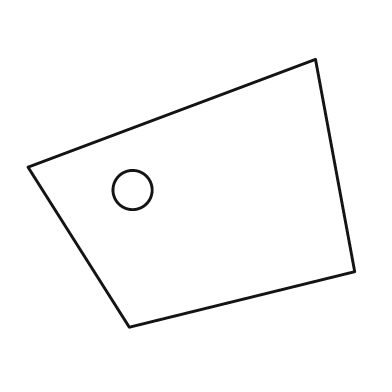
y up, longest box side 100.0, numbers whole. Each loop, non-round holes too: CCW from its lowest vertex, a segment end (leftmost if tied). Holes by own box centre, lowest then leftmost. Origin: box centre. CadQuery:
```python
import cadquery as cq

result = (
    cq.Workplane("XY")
    .moveTo(-19.0, -41.0)
    .lineTo(50.0, -24.0)
    .lineTo(38.0, 41.0)
    .lineTo(-50.0, 8.0)
    .close()
    .moveTo(-18.0, 1.0)
    .circle(6.0)
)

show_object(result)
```